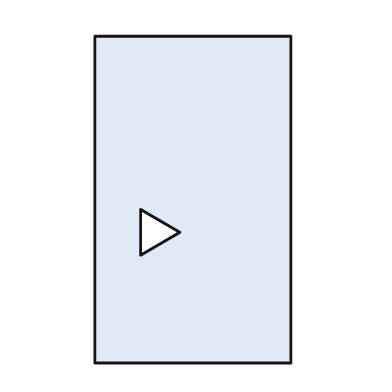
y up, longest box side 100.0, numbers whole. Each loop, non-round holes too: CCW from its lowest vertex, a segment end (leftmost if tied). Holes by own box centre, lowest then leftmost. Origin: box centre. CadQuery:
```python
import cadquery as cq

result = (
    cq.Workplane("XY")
    .moveTo(-30.0, -50.0)
    .lineTo(30.0, -50.0)
    .lineTo(30.0, 50.0)
    .lineTo(-30.0, 50.0)
    .close()
    .moveTo(-16.0, -17.0)
    .lineTo(-4.0, -10.0)
    .lineTo(-16.0, -3.0)
    .close()
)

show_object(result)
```